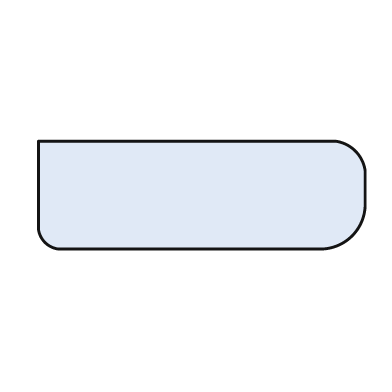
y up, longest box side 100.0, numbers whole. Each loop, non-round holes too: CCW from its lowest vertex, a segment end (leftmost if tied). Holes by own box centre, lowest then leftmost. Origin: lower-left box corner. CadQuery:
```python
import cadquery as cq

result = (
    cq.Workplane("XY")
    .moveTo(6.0, 0.0)
    .lineTo(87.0, 0.0)
    .threePointArc((96.0, 4.0), (100.0, 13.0))
    .lineTo(100.0, 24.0)
    .threePointArc((97.0, 30.0), (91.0, 33.0))
    .lineTo(0.0, 33.0)
    .lineTo(0.0, 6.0)
    .threePointArc((2.0, 2.0), (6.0, 0.0))
    .close()
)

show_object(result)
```